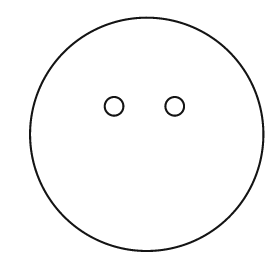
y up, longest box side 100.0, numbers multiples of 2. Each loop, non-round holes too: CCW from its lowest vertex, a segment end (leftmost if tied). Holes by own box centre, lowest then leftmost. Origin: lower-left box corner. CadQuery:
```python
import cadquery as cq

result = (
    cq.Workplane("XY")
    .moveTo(50.0, 50.0)
    .circle(50.0)
    .moveTo(36.0, 62.0)
    .circle(4.0)
    .moveTo(62.0, 62.0)
    .circle(4.0)
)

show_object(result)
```